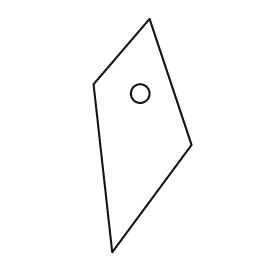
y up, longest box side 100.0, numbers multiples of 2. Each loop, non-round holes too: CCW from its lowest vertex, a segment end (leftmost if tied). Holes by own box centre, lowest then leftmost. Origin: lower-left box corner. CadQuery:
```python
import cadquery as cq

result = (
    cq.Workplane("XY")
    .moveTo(8.0, 0.0)
    .lineTo(42.0, 46.0)
    .lineTo(24.0, 100.0)
    .lineTo(0.0, 72.0)
    .close()
    .moveTo(20.0, 68.0)
    .circle(4.0)
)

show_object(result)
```